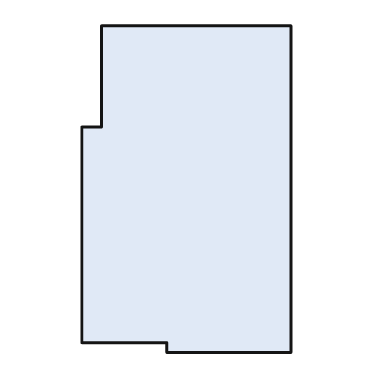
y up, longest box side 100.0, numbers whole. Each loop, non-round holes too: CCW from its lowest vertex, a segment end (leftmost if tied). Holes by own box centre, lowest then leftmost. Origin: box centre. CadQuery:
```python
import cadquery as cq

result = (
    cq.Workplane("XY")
    .moveTo(-6.0, -50.0)
    .lineTo(32.0, -50.0)
    .lineTo(32.0, 50.0)
    .lineTo(-26.0, 50.0)
    .lineTo(-26.0, 19.0)
    .lineTo(-32.0, 19.0)
    .lineTo(-32.0, -47.0)
    .lineTo(-6.0, -47.0)
    .close()
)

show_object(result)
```